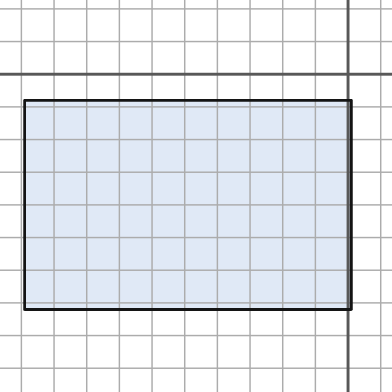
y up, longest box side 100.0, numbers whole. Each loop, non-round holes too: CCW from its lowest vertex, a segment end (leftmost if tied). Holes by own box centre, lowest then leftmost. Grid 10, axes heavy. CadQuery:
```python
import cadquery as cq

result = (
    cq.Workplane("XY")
    .moveTo(-99.0, -72.0)
    .lineTo(1.0, -72.0)
    .lineTo(1.0, -8.0)
    .lineTo(-99.0, -8.0)
    .close()
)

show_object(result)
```